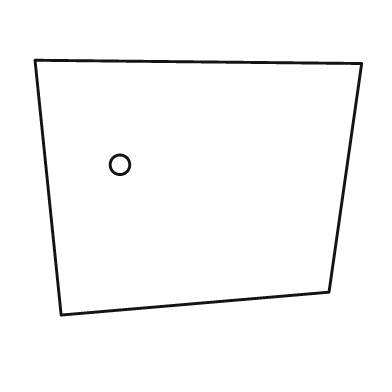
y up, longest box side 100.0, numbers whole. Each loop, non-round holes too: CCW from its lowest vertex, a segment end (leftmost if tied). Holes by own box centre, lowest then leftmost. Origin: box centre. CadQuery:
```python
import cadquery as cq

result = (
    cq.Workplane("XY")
    .moveTo(-42.0, -39.0)
    .lineTo(40.0, -32.0)
    .lineTo(50.0, 38.0)
    .lineTo(-50.0, 39.0)
    .close()
    .moveTo(-24.0, 7.0)
    .circle(3.0)
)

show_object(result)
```